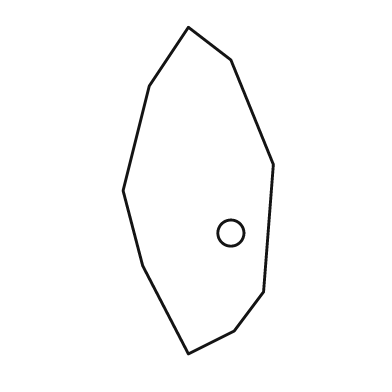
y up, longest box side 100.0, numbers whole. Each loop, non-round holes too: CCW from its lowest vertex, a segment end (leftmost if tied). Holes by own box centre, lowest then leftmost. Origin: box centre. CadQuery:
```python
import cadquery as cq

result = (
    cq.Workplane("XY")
    .moveTo(-3.0, -50.0)
    .lineTo(11.0, -43.0)
    .lineTo(20.0, -31.0)
    .lineTo(23.0, 8.0)
    .lineTo(10.0, 40.0)
    .lineTo(-3.0, 50.0)
    .lineTo(-15.0, 32.0)
    .lineTo(-23.0, 0.0)
    .lineTo(-17.0, -23.0)
    .close()
    .moveTo(10.0, -13.0)
    .circle(4.0)
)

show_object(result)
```